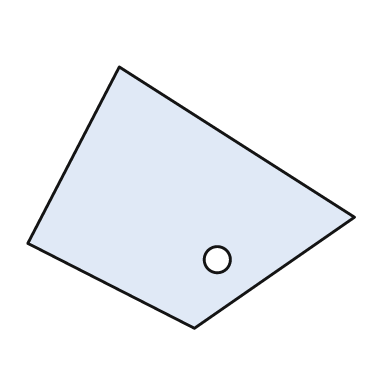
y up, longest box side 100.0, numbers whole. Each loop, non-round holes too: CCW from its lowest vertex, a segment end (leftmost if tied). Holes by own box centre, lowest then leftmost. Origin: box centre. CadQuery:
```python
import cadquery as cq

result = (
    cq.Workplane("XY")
    .moveTo(1.0, -40.0)
    .lineTo(50.0, -6.0)
    .lineTo(-22.0, 40.0)
    .lineTo(-50.0, -14.0)
    .close()
    .moveTo(8.0, -19.0)
    .circle(4.0)
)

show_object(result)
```